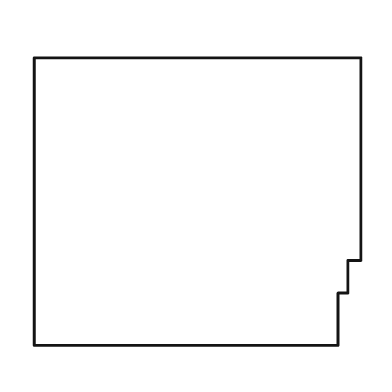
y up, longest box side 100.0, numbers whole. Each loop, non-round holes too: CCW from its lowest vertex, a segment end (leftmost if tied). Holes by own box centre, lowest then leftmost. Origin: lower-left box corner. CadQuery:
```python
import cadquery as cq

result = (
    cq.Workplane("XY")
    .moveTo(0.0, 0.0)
    .lineTo(93.0, 0.0)
    .lineTo(93.0, 16.0)
    .lineTo(96.0, 16.0)
    .lineTo(96.0, 26.0)
    .lineTo(100.0, 26.0)
    .lineTo(100.0, 88.0)
    .lineTo(0.0, 88.0)
    .close()
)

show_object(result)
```